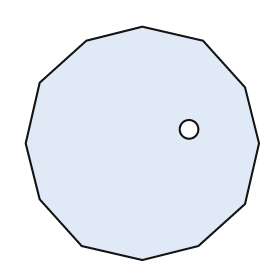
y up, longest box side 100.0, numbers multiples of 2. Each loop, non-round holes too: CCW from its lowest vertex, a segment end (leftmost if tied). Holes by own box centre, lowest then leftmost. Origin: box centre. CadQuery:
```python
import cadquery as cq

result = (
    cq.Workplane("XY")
    .moveTo(0.0, -50.0)
    .lineTo(24.0, -44.0)
    .lineTo(44.0, -26.0)
    .lineTo(50.0, 0.0)
    .lineTo(44.0, 24.0)
    .lineTo(26.0, 44.0)
    .lineTo(0.0, 50.0)
    .lineTo(-24.0, 44.0)
    .lineTo(-44.0, 26.0)
    .lineTo(-50.0, 0.0)
    .lineTo(-44.0, -24.0)
    .lineTo(-26.0, -44.0)
    .close()
    .moveTo(20.0, 6.0)
    .circle(4.0)
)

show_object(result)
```